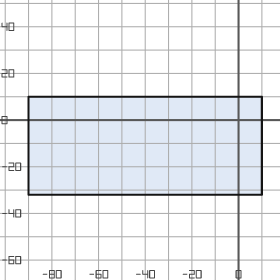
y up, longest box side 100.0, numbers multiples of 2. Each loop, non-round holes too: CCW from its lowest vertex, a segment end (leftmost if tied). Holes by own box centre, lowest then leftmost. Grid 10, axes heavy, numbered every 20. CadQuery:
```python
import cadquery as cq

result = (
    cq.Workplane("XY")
    .moveTo(-90.0, -32.0)
    .lineTo(10.0, -32.0)
    .lineTo(10.0, 10.0)
    .lineTo(-90.0, 10.0)
    .close()
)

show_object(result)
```